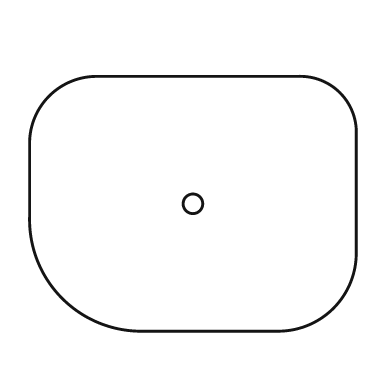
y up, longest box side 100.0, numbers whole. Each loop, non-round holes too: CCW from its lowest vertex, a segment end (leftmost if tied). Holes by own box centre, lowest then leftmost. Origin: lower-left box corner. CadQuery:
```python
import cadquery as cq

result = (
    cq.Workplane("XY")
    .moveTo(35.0, 0.0)
    .lineTo(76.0, 0.0)
    .threePointArc((93.0, 7.0), (100.0, 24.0))
    .lineTo(100.0, 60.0)
    .threePointArc((95.0, 73.0), (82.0, 78.0))
    .lineTo(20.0, 78.0)
    .threePointArc((6.0, 72.0), (0.0, 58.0))
    .lineTo(0.0, 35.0)
    .threePointArc((10.0, 10.0), (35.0, 0.0))
    .close()
    .moveTo(50.0, 39.0)
    .circle(3.0)
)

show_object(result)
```